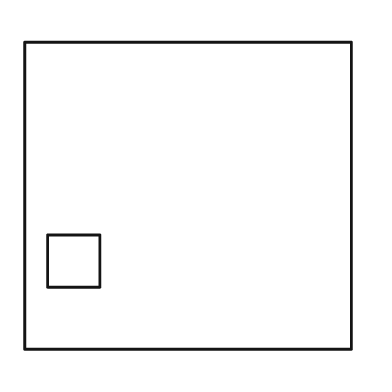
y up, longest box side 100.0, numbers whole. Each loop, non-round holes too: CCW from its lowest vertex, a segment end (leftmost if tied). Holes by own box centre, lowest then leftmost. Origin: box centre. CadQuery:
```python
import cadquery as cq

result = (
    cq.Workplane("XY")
    .moveTo(-50.0, -47.0)
    .lineTo(50.0, -47.0)
    .lineTo(50.0, 47.0)
    .lineTo(-50.0, 47.0)
    .close()
    .moveTo(-43.0, -28.0)
    .lineTo(-27.0, -28.0)
    .lineTo(-27.0, -12.0)
    .lineTo(-43.0, -12.0)
    .close()
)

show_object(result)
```